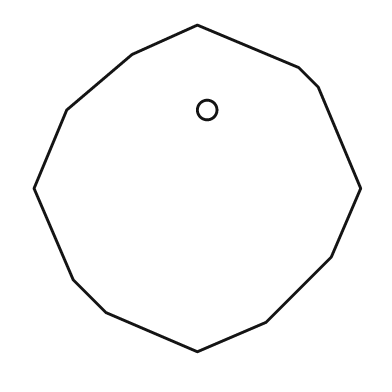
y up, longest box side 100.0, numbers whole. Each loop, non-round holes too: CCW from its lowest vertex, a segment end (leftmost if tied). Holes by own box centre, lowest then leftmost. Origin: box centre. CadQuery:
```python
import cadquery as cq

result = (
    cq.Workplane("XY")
    .moveTo(0.0, -50.0)
    .lineTo(21.0, -41.0)
    .lineTo(41.0, -21.0)
    .lineTo(50.0, 0.0)
    .lineTo(37.0, 31.0)
    .lineTo(31.0, 37.0)
    .lineTo(0.0, 50.0)
    .lineTo(-20.0, 41.0)
    .lineTo(-40.0, 24.0)
    .lineTo(-50.0, 0.0)
    .lineTo(-38.0, -28.0)
    .lineTo(-28.0, -38.0)
    .close()
    .moveTo(3.0, 24.0)
    .circle(3.0)
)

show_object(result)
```